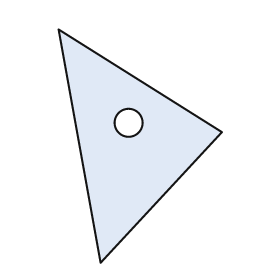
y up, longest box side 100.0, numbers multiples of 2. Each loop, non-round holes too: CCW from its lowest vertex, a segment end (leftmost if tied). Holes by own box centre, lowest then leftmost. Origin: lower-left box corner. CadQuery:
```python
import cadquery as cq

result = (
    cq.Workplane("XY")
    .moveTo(18.0, 0.0)
    .lineTo(70.0, 56.0)
    .lineTo(0.0, 100.0)
    .close()
    .moveTo(30.0, 60.0)
    .circle(6.0)
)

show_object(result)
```